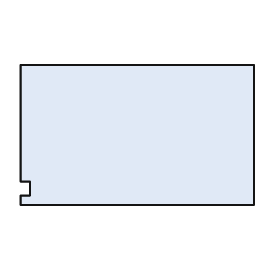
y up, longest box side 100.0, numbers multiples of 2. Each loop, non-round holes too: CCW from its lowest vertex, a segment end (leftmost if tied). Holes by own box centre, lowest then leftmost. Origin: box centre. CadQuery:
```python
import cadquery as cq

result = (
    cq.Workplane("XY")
    .moveTo(-50.0, -30.0)
    .lineTo(50.0, -30.0)
    .lineTo(50.0, 30.0)
    .lineTo(-50.0, 30.0)
    .lineTo(-50.0, -20.0)
    .lineTo(-46.0, -20.0)
    .lineTo(-46.0, -26.0)
    .lineTo(-50.0, -26.0)
    .close()
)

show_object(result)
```